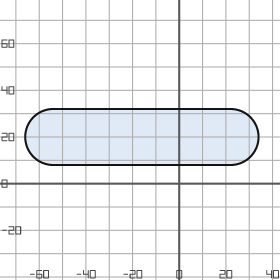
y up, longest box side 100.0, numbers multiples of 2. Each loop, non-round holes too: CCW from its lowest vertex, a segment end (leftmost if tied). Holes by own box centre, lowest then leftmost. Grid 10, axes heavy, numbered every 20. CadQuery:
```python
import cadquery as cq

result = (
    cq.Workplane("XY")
    .moveTo(-54.0, 8.0)
    .lineTo(22.0, 8.0)
    .threePointArc((34.0, 20.0), (22.0, 32.0))
    .lineTo(-54.0, 32.0)
    .threePointArc((-66.0, 20.0), (-54.0, 8.0))
    .close()
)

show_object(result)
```